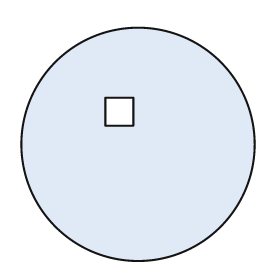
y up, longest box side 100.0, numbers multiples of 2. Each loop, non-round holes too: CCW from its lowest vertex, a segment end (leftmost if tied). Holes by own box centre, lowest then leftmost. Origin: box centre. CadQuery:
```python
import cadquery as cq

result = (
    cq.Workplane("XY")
    .moveTo(0.0, 0.0)
    .circle(50.0)
    .moveTo(-14.0, 8.0)
    .lineTo(-2.0, 8.0)
    .lineTo(-2.0, 20.0)
    .lineTo(-14.0, 20.0)
    .close()
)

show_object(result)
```